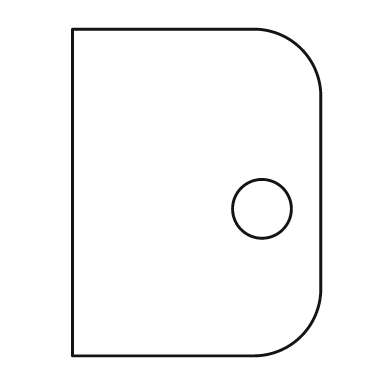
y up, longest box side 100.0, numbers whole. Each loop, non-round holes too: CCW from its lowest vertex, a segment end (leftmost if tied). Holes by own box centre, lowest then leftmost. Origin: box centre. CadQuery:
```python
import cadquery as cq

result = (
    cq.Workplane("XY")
    .moveTo(-38.0, -50.0)
    .lineTo(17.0, -50.0)
    .threePointArc((32.0, -44.0), (38.0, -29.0))
    .lineTo(38.0, 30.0)
    .threePointArc((32.0, 44.0), (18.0, 50.0))
    .lineTo(-38.0, 50.0)
    .close()
    .moveTo(20.0, -5.0)
    .circle(9.0)
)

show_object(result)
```